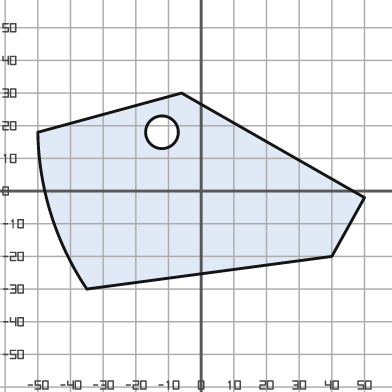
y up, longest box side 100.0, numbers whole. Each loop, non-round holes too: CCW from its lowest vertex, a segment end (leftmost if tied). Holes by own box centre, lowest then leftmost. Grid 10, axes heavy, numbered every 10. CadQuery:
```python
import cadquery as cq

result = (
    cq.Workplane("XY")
    .moveTo(-35.0, -30.0)
    .lineTo(40.0, -20.0)
    .lineTo(50.0, -2.0)
    .lineTo(-6.0, 30.0)
    .lineTo(-50.0, 18.0)
    .threePointArc((-46.0, -7.0), (-35.0, -30.0))
    .close()
    .moveTo(-12.0, 18.0)
    .circle(5.0)
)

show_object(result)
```